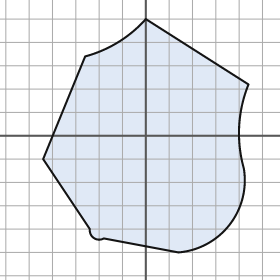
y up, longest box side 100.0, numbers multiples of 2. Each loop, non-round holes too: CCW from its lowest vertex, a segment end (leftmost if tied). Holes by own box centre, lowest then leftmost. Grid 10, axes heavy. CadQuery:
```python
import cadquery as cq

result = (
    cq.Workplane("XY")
    .moveTo(14.0, -50.0)
    .threePointArc((36.0, -38.0), (42.0, -14.0))
    .threePointArc((40.0, 4.0), (44.0, 22.0))
    .lineTo(0.0, 50.0)
    .threePointArc((-12.0, 40.0), (-26.0, 34.0))
    .lineTo(-44.0, -10.0)
    .lineTo(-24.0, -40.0)
    .threePointArc((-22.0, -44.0), (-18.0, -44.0))
    .close()
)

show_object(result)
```